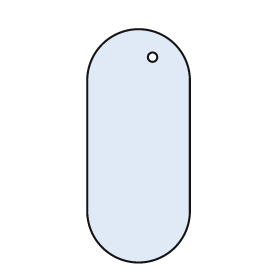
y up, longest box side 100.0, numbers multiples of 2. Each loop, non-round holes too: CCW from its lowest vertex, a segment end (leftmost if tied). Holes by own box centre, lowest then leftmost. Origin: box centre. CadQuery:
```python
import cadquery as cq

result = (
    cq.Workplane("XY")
    .moveTo(-22.0, -28.0)
    .threePointArc((0.0, -50.0), (22.0, -28.0))
    .lineTo(22.0, 28.0)
    .threePointArc((0.0, 50.0), (-22.0, 28.0))
    .close()
    .moveTo(6.0, 38.0)
    .circle(2.0)
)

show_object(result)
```